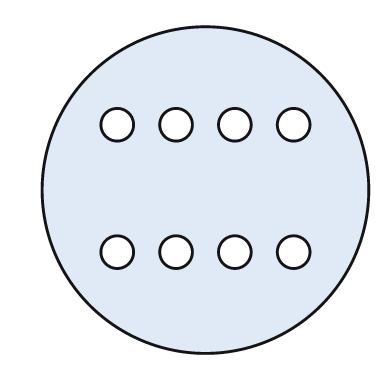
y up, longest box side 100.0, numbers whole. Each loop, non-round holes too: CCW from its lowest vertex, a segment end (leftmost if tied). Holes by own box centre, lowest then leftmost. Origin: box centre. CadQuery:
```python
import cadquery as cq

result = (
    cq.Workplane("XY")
    .moveTo(0.0, 0.0)
    .circle(50.0)
    .moveTo(-27.0, -19.0)
    .circle(5.0)
    .moveTo(-9.0, -19.0)
    .circle(5.0)
    .moveTo(9.0, -19.0)
    .circle(5.0)
    .moveTo(27.0, -19.0)
    .circle(5.0)
    .moveTo(-27.0, 20.0)
    .circle(5.0)
    .moveTo(-9.0, 20.0)
    .circle(5.0)
    .moveTo(9.0, 20.0)
    .circle(5.0)
    .moveTo(27.0, 20.0)
    .circle(5.0)
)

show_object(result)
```